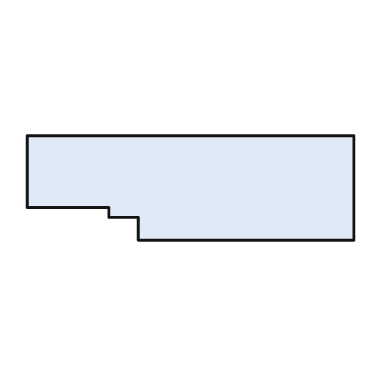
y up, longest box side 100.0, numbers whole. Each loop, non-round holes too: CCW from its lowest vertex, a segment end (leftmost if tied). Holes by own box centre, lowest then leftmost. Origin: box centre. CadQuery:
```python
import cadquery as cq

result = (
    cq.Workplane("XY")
    .moveTo(-16.0, -16.0)
    .lineTo(50.0, -16.0)
    .lineTo(50.0, 16.0)
    .lineTo(-50.0, 16.0)
    .lineTo(-50.0, -6.0)
    .lineTo(-25.0, -6.0)
    .lineTo(-25.0, -9.0)
    .lineTo(-16.0, -9.0)
    .close()
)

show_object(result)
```